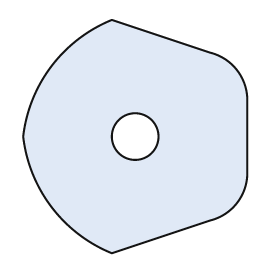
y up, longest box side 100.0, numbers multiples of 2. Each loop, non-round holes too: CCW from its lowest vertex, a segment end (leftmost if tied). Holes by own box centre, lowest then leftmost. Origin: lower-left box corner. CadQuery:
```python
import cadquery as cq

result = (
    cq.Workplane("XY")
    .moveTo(38.0, 0.0)
    .lineTo(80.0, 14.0)
    .threePointArc((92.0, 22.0), (96.0, 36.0))
    .lineTo(96.0, 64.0)
    .threePointArc((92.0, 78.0), (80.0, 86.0))
    .lineTo(38.0, 100.0)
    .threePointArc((12.0, 80.0), (0.0, 50.0))
    .threePointArc((12.0, 20.0), (38.0, 0.0))
    .close()
    .moveTo(48.0, 50.0)
    .circle(10.0)
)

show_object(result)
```